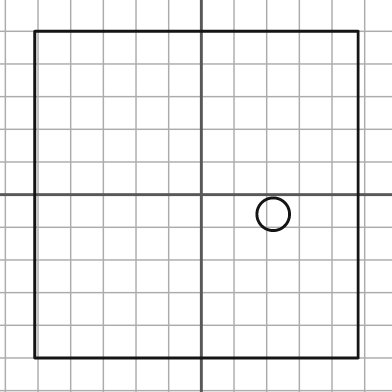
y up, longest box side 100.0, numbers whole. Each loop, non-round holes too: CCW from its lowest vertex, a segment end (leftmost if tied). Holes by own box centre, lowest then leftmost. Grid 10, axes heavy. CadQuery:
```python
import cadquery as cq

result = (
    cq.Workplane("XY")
    .moveTo(-51.0, -50.0)
    .lineTo(48.0, -50.0)
    .lineTo(48.0, 50.0)
    .lineTo(-51.0, 50.0)
    .close()
    .moveTo(22.0, -6.0)
    .circle(5.0)
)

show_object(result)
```